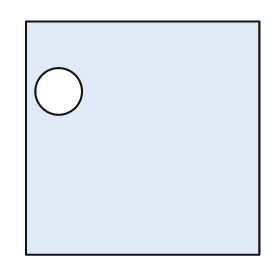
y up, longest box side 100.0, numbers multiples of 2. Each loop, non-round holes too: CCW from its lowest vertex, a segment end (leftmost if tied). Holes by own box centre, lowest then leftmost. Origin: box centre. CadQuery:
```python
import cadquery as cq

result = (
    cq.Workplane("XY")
    .moveTo(-50.0, -50.0)
    .lineTo(50.0, -50.0)
    .lineTo(50.0, 50.0)
    .lineTo(-50.0, 50.0)
    .close()
    .moveTo(-36.0, 20.0)
    .circle(10.0)
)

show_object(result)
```